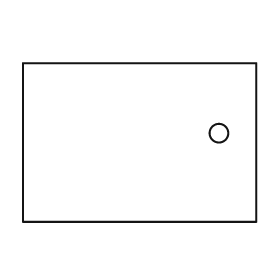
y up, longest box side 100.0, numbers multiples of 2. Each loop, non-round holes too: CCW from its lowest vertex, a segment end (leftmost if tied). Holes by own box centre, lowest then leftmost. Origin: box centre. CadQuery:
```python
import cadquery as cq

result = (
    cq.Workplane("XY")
    .moveTo(-50.0, -34.0)
    .lineTo(50.0, -34.0)
    .lineTo(50.0, 34.0)
    .lineTo(-50.0, 34.0)
    .close()
    .moveTo(34.0, 4.0)
    .circle(4.0)
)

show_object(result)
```